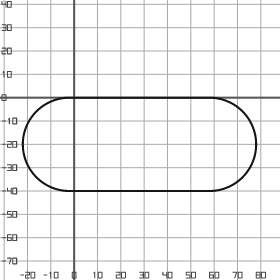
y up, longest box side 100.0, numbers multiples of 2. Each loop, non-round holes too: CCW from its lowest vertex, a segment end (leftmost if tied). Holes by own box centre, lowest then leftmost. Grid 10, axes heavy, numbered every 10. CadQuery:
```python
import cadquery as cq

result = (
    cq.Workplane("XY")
    .moveTo(-2.0, -40.0)
    .lineTo(58.0, -40.0)
    .threePointArc((78.0, -20.0), (58.0, 0.0))
    .lineTo(-2.0, 0.0)
    .threePointArc((-22.0, -20.0), (-2.0, -40.0))
    .close()
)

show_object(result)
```